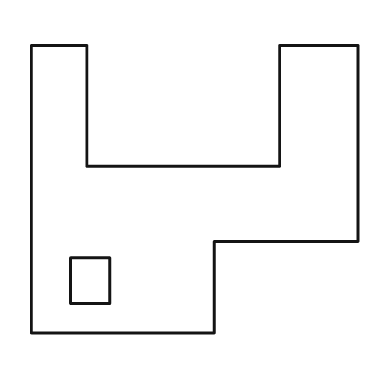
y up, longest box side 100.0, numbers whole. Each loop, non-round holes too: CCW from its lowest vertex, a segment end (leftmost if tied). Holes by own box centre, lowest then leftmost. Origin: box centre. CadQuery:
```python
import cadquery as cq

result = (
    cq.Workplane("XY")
    .moveTo(-50.0, -44.0)
    .lineTo(6.0, -44.0)
    .lineTo(6.0, -16.0)
    .lineTo(50.0, -16.0)
    .lineTo(50.0, 44.0)
    .lineTo(26.0, 44.0)
    .lineTo(26.0, 7.0)
    .lineTo(-33.0, 7.0)
    .lineTo(-33.0, 44.0)
    .lineTo(-50.0, 44.0)
    .close()
    .moveTo(-38.0, -35.0)
    .lineTo(-26.0, -35.0)
    .lineTo(-26.0, -21.0)
    .lineTo(-38.0, -21.0)
    .close()
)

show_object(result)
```